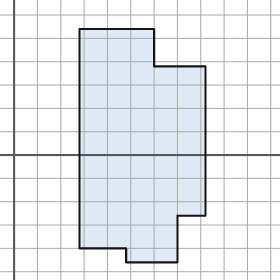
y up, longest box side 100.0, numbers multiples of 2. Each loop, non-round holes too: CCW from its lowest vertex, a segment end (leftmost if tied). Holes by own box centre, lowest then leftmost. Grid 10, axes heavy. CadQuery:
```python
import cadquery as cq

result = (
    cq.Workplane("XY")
    .moveTo(48.0, -46.0)
    .lineTo(70.0, -46.0)
    .lineTo(70.0, -26.0)
    .lineTo(82.0, -26.0)
    .lineTo(82.0, 38.0)
    .lineTo(60.0, 38.0)
    .lineTo(60.0, 54.0)
    .lineTo(28.0, 54.0)
    .lineTo(28.0, -40.0)
    .lineTo(48.0, -40.0)
    .close()
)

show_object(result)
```